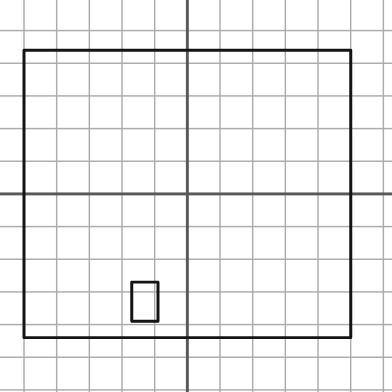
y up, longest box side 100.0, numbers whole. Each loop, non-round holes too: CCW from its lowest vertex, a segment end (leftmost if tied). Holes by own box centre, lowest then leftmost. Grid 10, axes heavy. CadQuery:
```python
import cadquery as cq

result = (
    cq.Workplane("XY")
    .moveTo(-50.0, -44.0)
    .lineTo(50.0, -44.0)
    .lineTo(50.0, 44.0)
    .lineTo(-50.0, 44.0)
    .close()
    .moveTo(-17.0, -39.0)
    .lineTo(-9.0, -39.0)
    .lineTo(-9.0, -27.0)
    .lineTo(-17.0, -27.0)
    .close()
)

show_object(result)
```